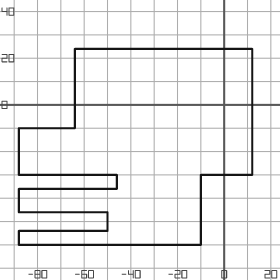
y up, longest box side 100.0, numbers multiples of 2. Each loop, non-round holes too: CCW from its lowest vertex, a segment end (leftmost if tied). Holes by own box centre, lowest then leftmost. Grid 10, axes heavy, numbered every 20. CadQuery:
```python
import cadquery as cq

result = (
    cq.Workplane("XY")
    .moveTo(-88.0, -60.0)
    .lineTo(-10.0, -60.0)
    .lineTo(-10.0, -30.0)
    .lineTo(12.0, -30.0)
    .lineTo(12.0, 24.0)
    .lineTo(-64.0, 24.0)
    .lineTo(-64.0, -10.0)
    .lineTo(-88.0, -10.0)
    .lineTo(-88.0, -30.0)
    .lineTo(-46.0, -30.0)
    .lineTo(-46.0, -36.0)
    .lineTo(-88.0, -36.0)
    .lineTo(-88.0, -46.0)
    .lineTo(-50.0, -46.0)
    .lineTo(-50.0, -54.0)
    .lineTo(-88.0, -54.0)
    .close()
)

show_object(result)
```